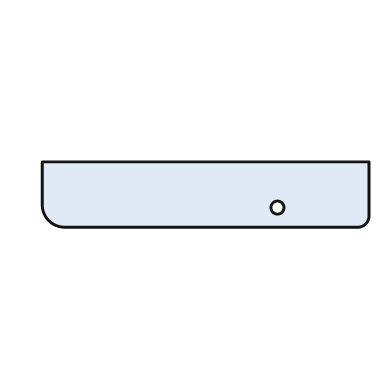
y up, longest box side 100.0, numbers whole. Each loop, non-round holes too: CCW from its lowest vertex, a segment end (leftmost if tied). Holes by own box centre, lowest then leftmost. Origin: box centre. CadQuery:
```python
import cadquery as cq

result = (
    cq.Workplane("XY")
    .moveTo(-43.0, -10.0)
    .lineTo(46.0, -10.0)
    .threePointArc((49.0, -9.0), (50.0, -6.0))
    .lineTo(50.0, 10.0)
    .lineTo(-50.0, 10.0)
    .lineTo(-50.0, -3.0)
    .threePointArc((-48.0, -8.0), (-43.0, -10.0))
    .close()
    .moveTo(22.0, -4.0)
    .circle(2.0)
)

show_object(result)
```